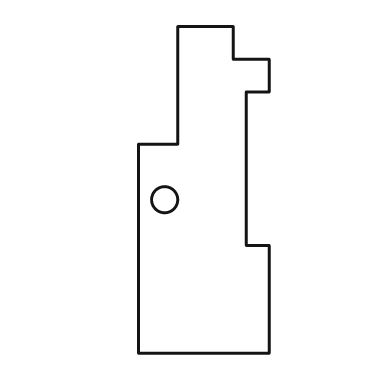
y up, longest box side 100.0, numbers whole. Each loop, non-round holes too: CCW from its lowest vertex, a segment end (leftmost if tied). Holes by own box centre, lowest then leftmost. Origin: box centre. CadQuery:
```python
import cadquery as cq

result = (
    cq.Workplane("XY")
    .moveTo(-20.0, -50.0)
    .lineTo(20.0, -50.0)
    .lineTo(20.0, -17.0)
    .lineTo(13.0, -17.0)
    .lineTo(13.0, 30.0)
    .lineTo(20.0, 30.0)
    .lineTo(20.0, 40.0)
    .lineTo(9.0, 40.0)
    .lineTo(9.0, 50.0)
    .lineTo(-8.0, 50.0)
    .lineTo(-8.0, 14.0)
    .lineTo(-20.0, 14.0)
    .close()
    .moveTo(-12.0, -3.0)
    .circle(4.0)
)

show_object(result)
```